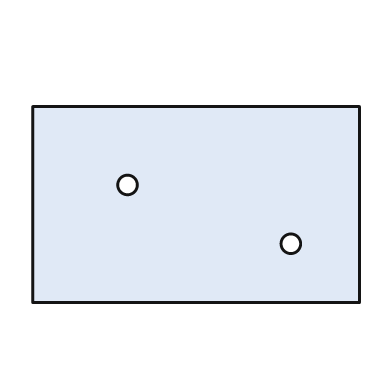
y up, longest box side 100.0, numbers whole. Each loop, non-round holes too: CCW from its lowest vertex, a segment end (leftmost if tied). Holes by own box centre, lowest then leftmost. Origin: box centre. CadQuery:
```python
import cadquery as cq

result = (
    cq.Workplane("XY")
    .moveTo(-50.0, -30.0)
    .lineTo(50.0, -30.0)
    .lineTo(50.0, 30.0)
    .lineTo(-50.0, 30.0)
    .close()
    .moveTo(29.0, -12.0)
    .circle(3.0)
    .moveTo(-21.0, 6.0)
    .circle(3.0)
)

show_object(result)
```